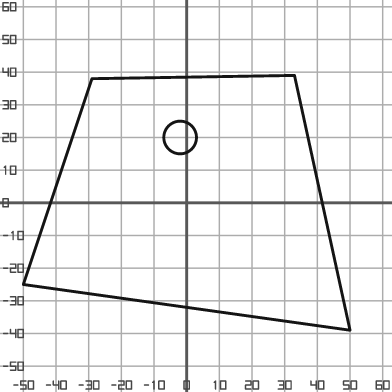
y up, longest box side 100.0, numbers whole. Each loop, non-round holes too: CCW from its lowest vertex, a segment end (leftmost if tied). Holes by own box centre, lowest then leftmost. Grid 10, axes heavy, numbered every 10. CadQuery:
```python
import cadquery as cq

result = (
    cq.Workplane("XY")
    .moveTo(50.0, -39.0)
    .lineTo(33.0, 39.0)
    .lineTo(-29.0, 38.0)
    .lineTo(-50.0, -25.0)
    .close()
    .moveTo(-2.0, 20.0)
    .circle(5.0)
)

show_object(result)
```